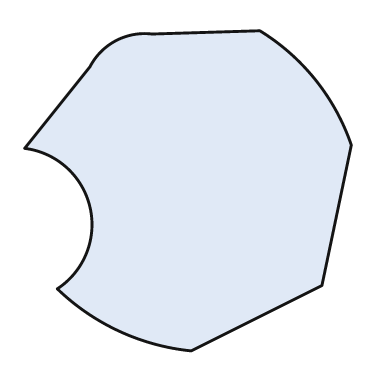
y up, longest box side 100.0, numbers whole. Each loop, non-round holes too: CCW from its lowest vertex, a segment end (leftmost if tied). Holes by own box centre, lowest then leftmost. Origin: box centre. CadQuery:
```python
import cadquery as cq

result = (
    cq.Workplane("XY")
    .moveTo(1.0, -49.0)
    .lineTo(41.0, -29.0)
    .lineTo(50.0, 14.0)
    .threePointArc((39.0, 34.0), (22.0, 49.0))
    .lineTo(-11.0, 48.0)
    .threePointArc((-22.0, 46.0), (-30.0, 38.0))
    .lineTo(-50.0, 13.0)
    .threePointArc((-30.0, -5.0), (-40.0, -30.0))
    .threePointArc((-21.0, -43.0), (1.0, -49.0))
    .close()
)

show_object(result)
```